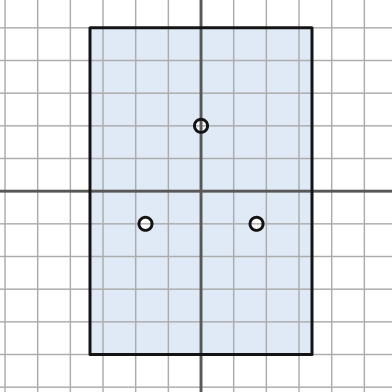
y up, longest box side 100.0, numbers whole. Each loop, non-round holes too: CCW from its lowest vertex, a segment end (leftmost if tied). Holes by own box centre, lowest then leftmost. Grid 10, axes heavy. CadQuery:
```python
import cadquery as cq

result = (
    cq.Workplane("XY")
    .moveTo(-34.0, -50.0)
    .lineTo(34.0, -50.0)
    .lineTo(34.0, 50.0)
    .lineTo(-34.0, 50.0)
    .close()
    .moveTo(-17.0, -10.0)
    .circle(2.0)
    .moveTo(17.0, -10.0)
    .circle(2.0)
    .moveTo(0.0, 20.0)
    .circle(2.0)
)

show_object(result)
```